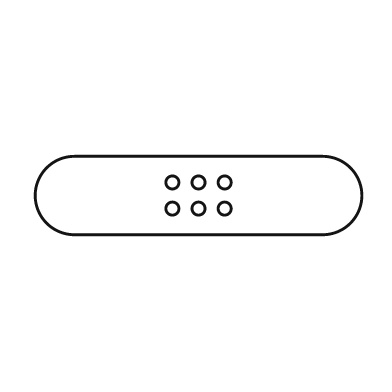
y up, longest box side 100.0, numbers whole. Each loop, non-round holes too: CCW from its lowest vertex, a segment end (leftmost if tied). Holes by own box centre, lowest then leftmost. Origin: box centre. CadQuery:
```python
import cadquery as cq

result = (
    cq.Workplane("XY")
    .moveTo(-38.0, -12.0)
    .lineTo(38.0, -12.0)
    .threePointArc((50.0, 0.0), (38.0, 12.0))
    .lineTo(-38.0, 12.0)
    .threePointArc((-50.0, 0.0), (-38.0, -12.0))
    .close()
    .moveTo(-8.0, -4.0)
    .circle(2.0)
    .moveTo(0.0, -4.0)
    .circle(2.0)
    .moveTo(8.0, -4.0)
    .circle(2.0)
    .moveTo(-8.0, 4.0)
    .circle(2.0)
    .moveTo(0.0, 4.0)
    .circle(2.0)
    .moveTo(8.0, 4.0)
    .circle(2.0)
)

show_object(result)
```